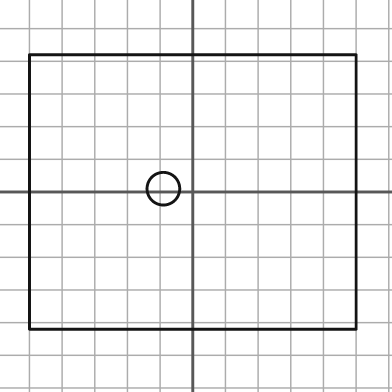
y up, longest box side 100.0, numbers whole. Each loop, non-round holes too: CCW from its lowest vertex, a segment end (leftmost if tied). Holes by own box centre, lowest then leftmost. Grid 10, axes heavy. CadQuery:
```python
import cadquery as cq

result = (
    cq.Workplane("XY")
    .moveTo(-50.0, -42.0)
    .lineTo(50.0, -42.0)
    .lineTo(50.0, 42.0)
    .lineTo(-50.0, 42.0)
    .close()
    .moveTo(-9.0, 1.0)
    .circle(5.0)
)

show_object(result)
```